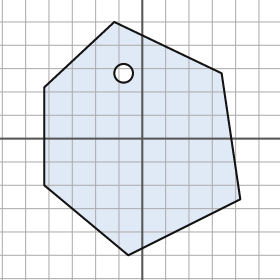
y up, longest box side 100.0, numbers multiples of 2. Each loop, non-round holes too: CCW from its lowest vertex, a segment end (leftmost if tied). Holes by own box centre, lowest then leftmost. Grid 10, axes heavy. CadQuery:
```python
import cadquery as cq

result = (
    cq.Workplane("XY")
    .moveTo(-6.0, -50.0)
    .lineTo(42.0, -26.0)
    .lineTo(34.0, 28.0)
    .lineTo(-12.0, 50.0)
    .lineTo(-42.0, 22.0)
    .lineTo(-42.0, -20.0)
    .close()
    .moveTo(-8.0, 28.0)
    .circle(4.0)
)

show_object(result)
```